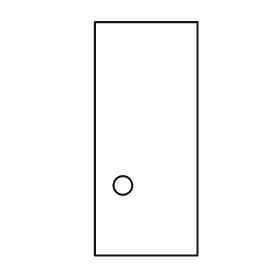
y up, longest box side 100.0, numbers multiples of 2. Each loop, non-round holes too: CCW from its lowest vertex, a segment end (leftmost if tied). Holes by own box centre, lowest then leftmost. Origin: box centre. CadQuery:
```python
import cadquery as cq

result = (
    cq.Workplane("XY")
    .moveTo(-22.0, -50.0)
    .lineTo(22.0, -50.0)
    .lineTo(22.0, 50.0)
    .lineTo(-22.0, 50.0)
    .close()
    .moveTo(-10.0, -20.0)
    .circle(4.0)
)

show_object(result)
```